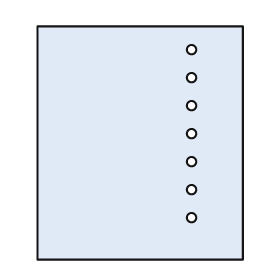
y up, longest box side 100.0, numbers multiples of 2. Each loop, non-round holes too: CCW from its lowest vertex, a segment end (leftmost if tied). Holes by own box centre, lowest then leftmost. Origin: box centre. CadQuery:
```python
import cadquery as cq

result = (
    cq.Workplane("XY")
    .moveTo(-44.0, -50.0)
    .lineTo(44.0, -50.0)
    .lineTo(44.0, 50.0)
    .lineTo(-44.0, 50.0)
    .close()
    .moveTo(22.0, -32.0)
    .circle(2.0)
    .moveTo(22.0, -20.0)
    .circle(2.0)
    .moveTo(22.0, -8.0)
    .circle(2.0)
    .moveTo(22.0, 4.0)
    .circle(2.0)
    .moveTo(22.0, 16.0)
    .circle(2.0)
    .moveTo(22.0, 28.0)
    .circle(2.0)
    .moveTo(22.0, 40.0)
    .circle(2.0)
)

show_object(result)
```